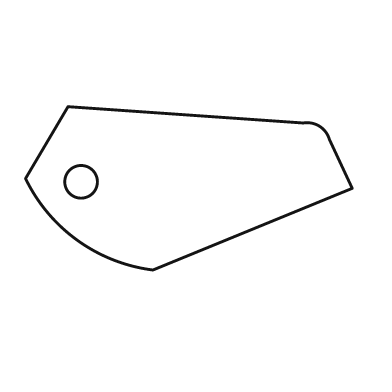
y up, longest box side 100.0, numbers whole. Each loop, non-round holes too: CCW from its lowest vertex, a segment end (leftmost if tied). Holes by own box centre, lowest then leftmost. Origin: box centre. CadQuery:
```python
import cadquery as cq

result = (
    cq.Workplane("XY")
    .moveTo(-11.0, -25.0)
    .lineTo(50.0, 0.0)
    .lineTo(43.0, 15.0)
    .threePointArc((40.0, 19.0), (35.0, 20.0))
    .lineTo(-37.0, 25.0)
    .lineTo(-50.0, 3.0)
    .threePointArc((-34.0, -16.0), (-11.0, -25.0))
    .close()
    .moveTo(-33.0, 2.0)
    .circle(5.0)
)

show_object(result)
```